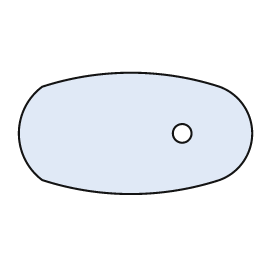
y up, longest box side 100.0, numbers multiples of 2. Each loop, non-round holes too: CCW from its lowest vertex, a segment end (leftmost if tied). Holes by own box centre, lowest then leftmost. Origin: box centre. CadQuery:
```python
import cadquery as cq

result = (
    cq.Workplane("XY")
    .moveTo(-40.0, -20.0)
    .threePointArc((-2.0, -26.0), (36.0, -20.0))
    .threePointArc((50.0, 0.0), (36.0, 20.0))
    .threePointArc((-2.0, 26.0), (-40.0, 20.0))
    .threePointArc((-50.0, 0.0), (-40.0, -20.0))
    .close()
    .moveTo(20.0, 0.0)
    .circle(4.0)
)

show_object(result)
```